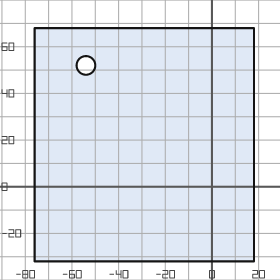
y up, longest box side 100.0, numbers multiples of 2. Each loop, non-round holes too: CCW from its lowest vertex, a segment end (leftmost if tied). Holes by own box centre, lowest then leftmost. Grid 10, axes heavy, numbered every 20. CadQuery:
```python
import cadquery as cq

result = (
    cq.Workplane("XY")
    .moveTo(-76.0, -32.0)
    .lineTo(18.0, -32.0)
    .lineTo(18.0, 68.0)
    .lineTo(-76.0, 68.0)
    .close()
    .moveTo(-54.0, 52.0)
    .circle(4.0)
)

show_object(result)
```